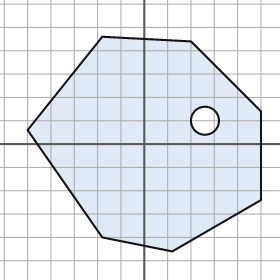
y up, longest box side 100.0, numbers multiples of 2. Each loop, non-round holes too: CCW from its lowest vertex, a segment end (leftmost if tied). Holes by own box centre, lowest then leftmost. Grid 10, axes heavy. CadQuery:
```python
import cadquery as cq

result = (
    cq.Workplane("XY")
    .moveTo(12.0, -46.0)
    .lineTo(50.0, -24.0)
    .lineTo(50.0, 14.0)
    .lineTo(20.0, 44.0)
    .lineTo(-18.0, 46.0)
    .lineTo(-50.0, 6.0)
    .lineTo(-18.0, -40.0)
    .close()
    .moveTo(26.0, 10.0)
    .circle(6.0)
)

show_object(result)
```